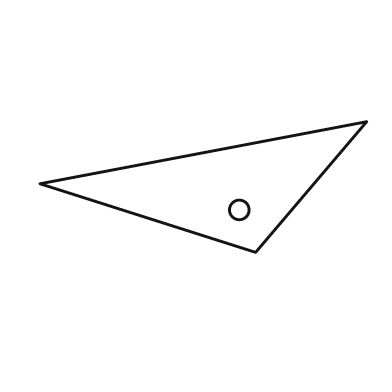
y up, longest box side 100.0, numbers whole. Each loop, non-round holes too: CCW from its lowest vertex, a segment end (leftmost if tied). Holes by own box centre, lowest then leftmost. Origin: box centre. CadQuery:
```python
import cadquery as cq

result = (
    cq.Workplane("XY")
    .moveTo(16.0, -20.0)
    .lineTo(50.0, 20.0)
    .lineTo(-50.0, 1.0)
    .close()
    .moveTo(11.0, -7.0)
    .circle(3.0)
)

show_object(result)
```